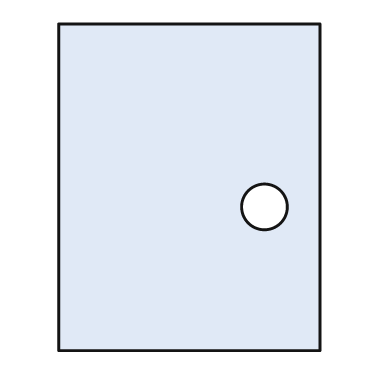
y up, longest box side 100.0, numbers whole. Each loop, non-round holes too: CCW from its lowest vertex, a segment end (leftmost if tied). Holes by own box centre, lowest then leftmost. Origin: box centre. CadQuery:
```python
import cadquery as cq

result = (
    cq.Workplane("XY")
    .moveTo(-40.0, -50.0)
    .lineTo(40.0, -50.0)
    .lineTo(40.0, 50.0)
    .lineTo(-40.0, 50.0)
    .close()
    .moveTo(23.0, -6.0)
    .circle(7.0)
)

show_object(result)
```